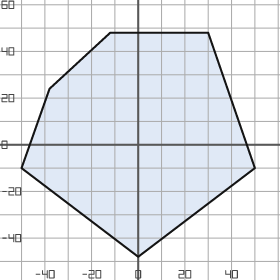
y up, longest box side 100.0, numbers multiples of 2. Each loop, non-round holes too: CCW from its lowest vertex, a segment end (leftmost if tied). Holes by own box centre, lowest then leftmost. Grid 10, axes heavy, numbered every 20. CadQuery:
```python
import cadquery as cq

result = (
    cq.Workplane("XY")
    .moveTo(0.0, -48.0)
    .lineTo(50.0, -10.0)
    .lineTo(30.0, 48.0)
    .lineTo(-12.0, 48.0)
    .lineTo(-38.0, 24.0)
    .lineTo(-50.0, -10.0)
    .close()
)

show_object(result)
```